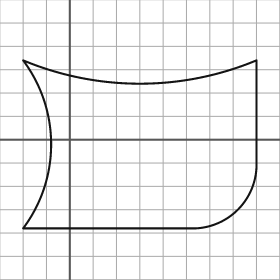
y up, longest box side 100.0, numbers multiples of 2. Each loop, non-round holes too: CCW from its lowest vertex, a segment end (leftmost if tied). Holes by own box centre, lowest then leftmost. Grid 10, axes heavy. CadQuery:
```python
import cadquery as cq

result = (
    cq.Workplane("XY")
    .moveTo(-20.0, -38.0)
    .lineTo(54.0, -38.0)
    .threePointArc((72.0, -30.0), (80.0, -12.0))
    .lineTo(80.0, 34.0)
    .threePointArc((30.0, 24.0), (-20.0, 34.0))
    .threePointArc((-8.0, -2.0), (-20.0, -38.0))
    .close()
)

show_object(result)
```